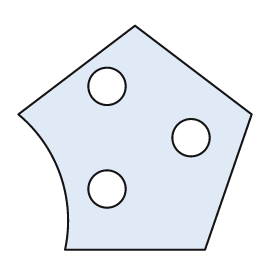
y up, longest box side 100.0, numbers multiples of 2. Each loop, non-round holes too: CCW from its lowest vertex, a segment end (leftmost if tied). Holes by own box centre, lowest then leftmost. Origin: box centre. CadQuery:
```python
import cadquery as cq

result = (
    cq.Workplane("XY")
    .moveTo(-30.0, -48.0)
    .lineTo(30.0, -48.0)
    .lineTo(50.0, 10.0)
    .lineTo(0.0, 48.0)
    .lineTo(-50.0, 10.0)
    .threePointArc((-32.0, -16.0), (-30.0, -48.0))
    .close()
    .moveTo(-12.0, -22.0)
    .circle(8.0)
    .moveTo(24.0, 0.0)
    .circle(8.0)
    .moveTo(-12.0, 22.0)
    .circle(8.0)
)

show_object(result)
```